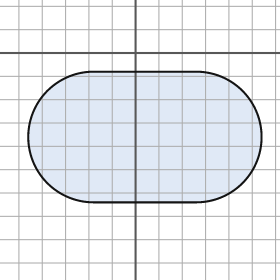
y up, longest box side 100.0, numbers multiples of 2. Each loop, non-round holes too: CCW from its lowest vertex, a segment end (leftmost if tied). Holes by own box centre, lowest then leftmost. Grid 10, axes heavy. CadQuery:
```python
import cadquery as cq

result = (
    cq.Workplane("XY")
    .moveTo(-18.0, -64.0)
    .lineTo(26.0, -64.0)
    .threePointArc((54.0, -36.0), (26.0, -8.0))
    .lineTo(-18.0, -8.0)
    .threePointArc((-46.0, -36.0), (-18.0, -64.0))
    .close()
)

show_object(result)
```